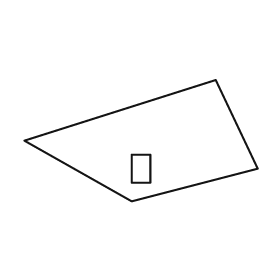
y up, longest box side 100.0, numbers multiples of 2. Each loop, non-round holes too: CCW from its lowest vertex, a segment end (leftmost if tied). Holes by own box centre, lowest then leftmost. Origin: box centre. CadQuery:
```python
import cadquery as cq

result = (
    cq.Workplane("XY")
    .moveTo(-4.0, -26.0)
    .lineTo(50.0, -12.0)
    .lineTo(32.0, 26.0)
    .lineTo(-50.0, 0.0)
    .close()
    .moveTo(-4.0, -18.0)
    .lineTo(4.0, -18.0)
    .lineTo(4.0, -6.0)
    .lineTo(-4.0, -6.0)
    .close()
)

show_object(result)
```